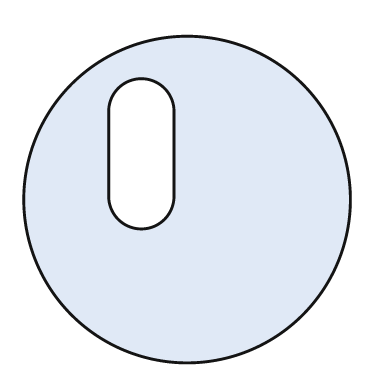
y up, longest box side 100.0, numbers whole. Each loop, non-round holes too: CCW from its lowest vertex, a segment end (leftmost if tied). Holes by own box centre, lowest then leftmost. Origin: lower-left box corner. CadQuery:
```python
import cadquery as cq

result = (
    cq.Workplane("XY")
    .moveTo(50.0, 50.0)
    .circle(50.0)
    .moveTo(26.0, 51.0)
    .threePointArc((36.0, 41.0), (46.0, 51.0))
    .lineTo(46.0, 77.0)
    .threePointArc((36.0, 87.0), (26.0, 77.0))
    .close()
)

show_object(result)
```